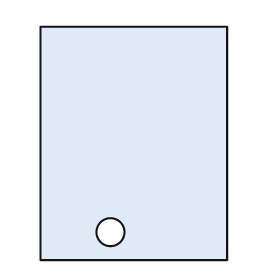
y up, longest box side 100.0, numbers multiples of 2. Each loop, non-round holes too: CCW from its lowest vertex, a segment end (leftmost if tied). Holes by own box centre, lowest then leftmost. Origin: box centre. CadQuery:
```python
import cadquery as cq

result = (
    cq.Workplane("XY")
    .moveTo(-40.0, -50.0)
    .lineTo(40.0, -50.0)
    .lineTo(40.0, 50.0)
    .lineTo(-40.0, 50.0)
    .close()
    .moveTo(-10.0, -38.0)
    .circle(6.0)
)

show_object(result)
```